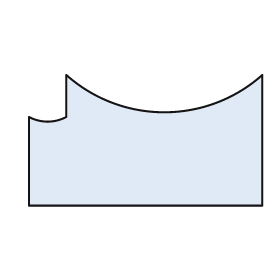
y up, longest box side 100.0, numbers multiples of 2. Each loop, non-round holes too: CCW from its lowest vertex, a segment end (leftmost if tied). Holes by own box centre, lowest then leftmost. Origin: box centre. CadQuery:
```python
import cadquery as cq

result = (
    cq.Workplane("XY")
    .moveTo(-50.0, -28.0)
    .lineTo(50.0, -28.0)
    .lineTo(50.0, 28.0)
    .threePointArc((8.0, 12.0), (-34.0, 28.0))
    .lineTo(-34.0, 10.0)
    .threePointArc((-42.0, 8.0), (-50.0, 10.0))
    .close()
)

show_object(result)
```